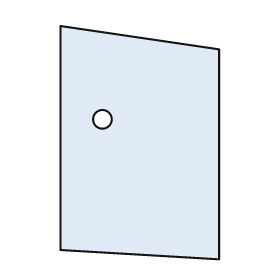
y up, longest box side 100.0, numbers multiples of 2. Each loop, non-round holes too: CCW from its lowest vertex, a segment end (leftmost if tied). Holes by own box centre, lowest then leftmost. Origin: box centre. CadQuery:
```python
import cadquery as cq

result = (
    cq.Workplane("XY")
    .moveTo(34.0, -50.0)
    .lineTo(34.0, 40.0)
    .lineTo(-34.0, 50.0)
    .lineTo(-34.0, -46.0)
    .close()
    .moveTo(-16.0, 10.0)
    .circle(4.0)
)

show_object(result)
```